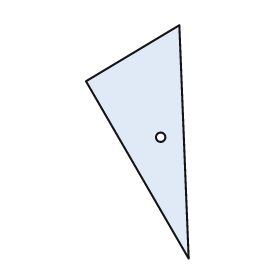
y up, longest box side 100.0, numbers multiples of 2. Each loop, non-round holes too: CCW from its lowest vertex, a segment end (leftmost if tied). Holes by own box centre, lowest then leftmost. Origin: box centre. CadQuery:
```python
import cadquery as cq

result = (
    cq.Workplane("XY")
    .moveTo(22.0, -50.0)
    .lineTo(18.0, 50.0)
    .lineTo(-22.0, 26.0)
    .close()
    .moveTo(10.0, 2.0)
    .circle(2.0)
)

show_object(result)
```